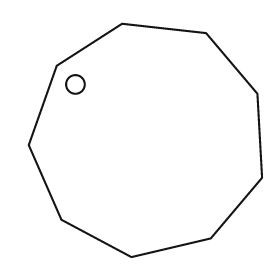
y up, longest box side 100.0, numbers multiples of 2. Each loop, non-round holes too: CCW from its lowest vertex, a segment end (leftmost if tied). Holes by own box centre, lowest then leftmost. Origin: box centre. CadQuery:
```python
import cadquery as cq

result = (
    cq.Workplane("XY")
    .moveTo(-6.0, -50.0)
    .lineTo(28.0, -42.0)
    .lineTo(50.0, -16.0)
    .lineTo(48.0, 20.0)
    .lineTo(26.0, 46.0)
    .lineTo(-10.0, 50.0)
    .lineTo(-38.0, 32.0)
    .lineTo(-50.0, -2.0)
    .lineTo(-36.0, -34.0)
    .close()
    .moveTo(-30.0, 24.0)
    .circle(4.0)
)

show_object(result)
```